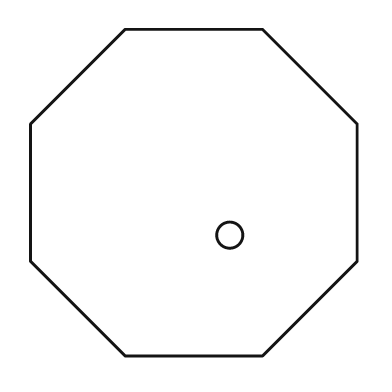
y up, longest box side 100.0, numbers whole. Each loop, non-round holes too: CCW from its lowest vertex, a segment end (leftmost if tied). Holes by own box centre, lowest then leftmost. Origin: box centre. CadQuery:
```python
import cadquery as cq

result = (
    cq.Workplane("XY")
    .moveTo(-21.0, -50.0)
    .lineTo(21.0, -50.0)
    .lineTo(50.0, -21.0)
    .lineTo(50.0, 21.0)
    .lineTo(21.0, 50.0)
    .lineTo(-21.0, 50.0)
    .lineTo(-50.0, 21.0)
    .lineTo(-50.0, -21.0)
    .close()
    .moveTo(11.0, -13.0)
    .circle(4.0)
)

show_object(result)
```